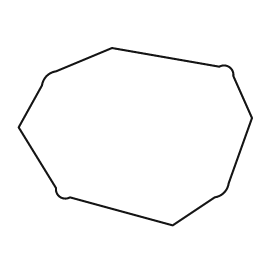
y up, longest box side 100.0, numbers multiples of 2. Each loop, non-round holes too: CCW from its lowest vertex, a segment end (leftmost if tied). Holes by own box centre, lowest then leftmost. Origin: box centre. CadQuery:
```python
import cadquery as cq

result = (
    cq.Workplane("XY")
    .moveTo(16.0, -38.0)
    .lineTo(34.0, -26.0)
    .threePointArc((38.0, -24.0), (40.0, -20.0))
    .lineTo(50.0, 8.0)
    .lineTo(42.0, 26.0)
    .threePointArc((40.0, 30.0), (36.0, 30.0))
    .lineTo(-10.0, 38.0)
    .lineTo(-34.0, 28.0)
    .threePointArc((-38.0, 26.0), (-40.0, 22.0))
    .lineTo(-50.0, 4.0)
    .lineTo(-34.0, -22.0)
    .threePointArc((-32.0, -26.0), (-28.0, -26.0))
    .close()
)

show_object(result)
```